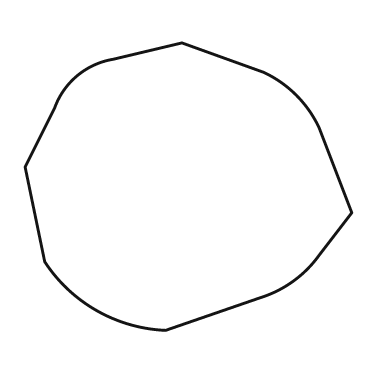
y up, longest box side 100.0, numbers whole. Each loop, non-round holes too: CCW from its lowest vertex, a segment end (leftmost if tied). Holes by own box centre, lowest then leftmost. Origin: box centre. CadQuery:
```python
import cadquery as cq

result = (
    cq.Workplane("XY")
    .moveTo(-7.0, -44.0)
    .lineTo(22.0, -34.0)
    .threePointArc((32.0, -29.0), (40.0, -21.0))
    .lineTo(50.0, -8.0)
    .lineTo(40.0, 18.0)
    .threePointArc((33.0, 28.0), (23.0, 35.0))
    .lineTo(-2.0, 44.0)
    .lineTo(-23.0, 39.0)
    .threePointArc((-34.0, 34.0), (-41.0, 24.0))
    .lineTo(-50.0, 6.0)
    .lineTo(-44.0, -23.0)
    .threePointArc((-28.0, -38.0), (-7.0, -44.0))
    .close()
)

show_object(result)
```